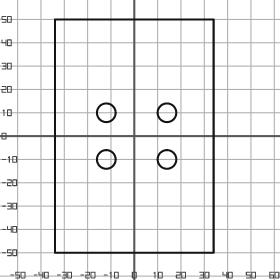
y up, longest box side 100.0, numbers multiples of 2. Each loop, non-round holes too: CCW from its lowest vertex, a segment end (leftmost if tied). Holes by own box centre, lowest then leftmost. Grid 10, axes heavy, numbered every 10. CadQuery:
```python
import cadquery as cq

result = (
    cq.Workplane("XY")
    .moveTo(-34.0, -50.0)
    .lineTo(34.0, -50.0)
    .lineTo(34.0, 50.0)
    .lineTo(-34.0, 50.0)
    .close()
    .moveTo(-12.0, -10.0)
    .circle(4.0)
    .moveTo(14.0, -10.0)
    .circle(4.0)
    .moveTo(-12.0, 10.0)
    .circle(4.0)
    .moveTo(14.0, 10.0)
    .circle(4.0)
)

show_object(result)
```